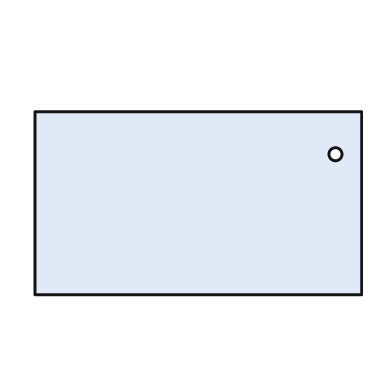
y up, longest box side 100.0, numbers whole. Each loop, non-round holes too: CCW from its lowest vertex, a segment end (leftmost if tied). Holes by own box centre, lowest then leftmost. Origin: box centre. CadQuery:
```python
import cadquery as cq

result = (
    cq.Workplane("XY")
    .moveTo(-50.0, -28.0)
    .lineTo(50.0, -28.0)
    .lineTo(50.0, 28.0)
    .lineTo(-50.0, 28.0)
    .close()
    .moveTo(42.0, 15.0)
    .circle(2.0)
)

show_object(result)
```